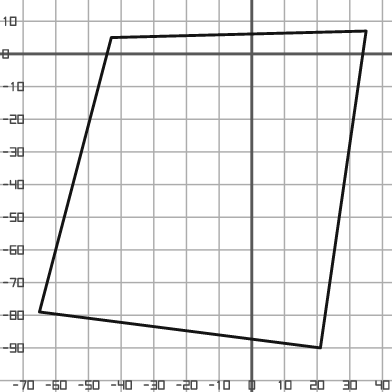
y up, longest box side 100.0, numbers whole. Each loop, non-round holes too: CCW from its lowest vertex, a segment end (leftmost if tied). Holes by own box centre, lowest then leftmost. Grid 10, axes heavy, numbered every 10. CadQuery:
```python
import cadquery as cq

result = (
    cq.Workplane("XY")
    .moveTo(21.0, -90.0)
    .lineTo(35.0, 7.0)
    .lineTo(-43.0, 5.0)
    .lineTo(-65.0, -79.0)
    .close()
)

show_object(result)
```